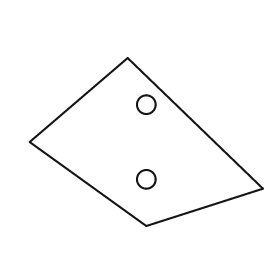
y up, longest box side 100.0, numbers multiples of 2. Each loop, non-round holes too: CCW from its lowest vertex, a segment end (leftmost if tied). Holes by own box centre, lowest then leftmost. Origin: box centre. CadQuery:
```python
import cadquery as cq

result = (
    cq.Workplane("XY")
    .moveTo(0.0, -36.0)
    .lineTo(50.0, -20.0)
    .lineTo(-8.0, 36.0)
    .lineTo(-50.0, 0.0)
    .close()
    .moveTo(0.0, -16.0)
    .circle(4.0)
    .moveTo(0.0, 16.0)
    .circle(4.0)
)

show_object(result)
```